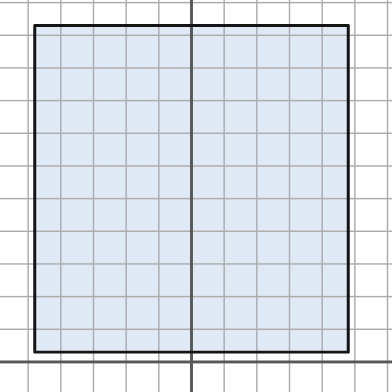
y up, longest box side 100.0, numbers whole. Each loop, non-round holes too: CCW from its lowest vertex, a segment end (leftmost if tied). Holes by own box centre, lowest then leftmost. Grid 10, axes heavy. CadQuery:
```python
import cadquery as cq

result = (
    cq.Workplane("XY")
    .moveTo(-48.0, 3.0)
    .lineTo(48.0, 3.0)
    .lineTo(48.0, 103.0)
    .lineTo(-48.0, 103.0)
    .close()
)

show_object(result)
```